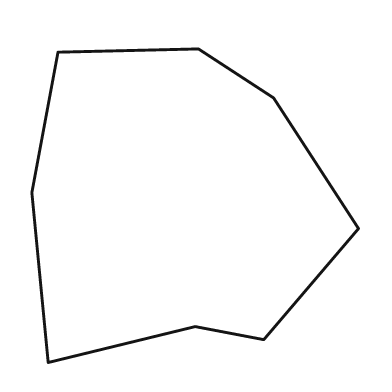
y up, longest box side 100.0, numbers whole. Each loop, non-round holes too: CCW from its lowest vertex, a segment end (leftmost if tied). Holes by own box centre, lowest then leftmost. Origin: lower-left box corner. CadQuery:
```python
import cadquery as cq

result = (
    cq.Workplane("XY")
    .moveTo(5.0, 0.0)
    .lineTo(50.0, 11.0)
    .lineTo(71.0, 7.0)
    .lineTo(100.0, 41.0)
    .lineTo(74.0, 81.0)
    .lineTo(51.0, 96.0)
    .lineTo(8.0, 95.0)
    .lineTo(0.0, 52.0)
    .close()
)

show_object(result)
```